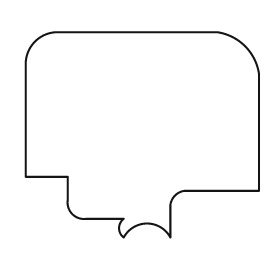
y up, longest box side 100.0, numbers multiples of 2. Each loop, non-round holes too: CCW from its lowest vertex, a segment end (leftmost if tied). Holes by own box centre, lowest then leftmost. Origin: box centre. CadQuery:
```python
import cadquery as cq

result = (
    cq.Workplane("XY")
    .moveTo(-8.0, -44.0)
    .threePointArc((2.0, -38.0), (12.0, -44.0))
    .lineTo(12.0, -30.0)
    .threePointArc((14.0, -26.0), (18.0, -24.0))
    .lineTo(50.0, -24.0)
    .lineTo(50.0, 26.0)
    .threePointArc((44.0, 38.0), (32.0, 44.0))
    .lineTo(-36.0, 44.0)
    .threePointArc((-46.0, 40.0), (-50.0, 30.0))
    .lineTo(-50.0, -18.0)
    .lineTo(-32.0, -18.0)
    .lineTo(-32.0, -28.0)
    .threePointArc((-30.0, -34.0), (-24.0, -36.0))
    .lineTo(-8.0, -36.0)
    .threePointArc((-10.0, -40.0), (-8.0, -44.0))
    .close()
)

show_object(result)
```